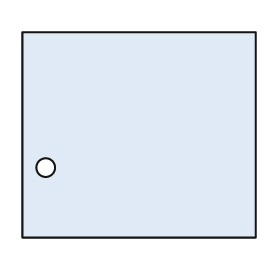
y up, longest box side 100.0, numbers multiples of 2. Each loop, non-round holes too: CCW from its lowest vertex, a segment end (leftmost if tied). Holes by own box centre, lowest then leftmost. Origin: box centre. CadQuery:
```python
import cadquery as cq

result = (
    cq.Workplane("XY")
    .moveTo(-50.0, -44.0)
    .lineTo(50.0, -44.0)
    .lineTo(50.0, 44.0)
    .lineTo(-50.0, 44.0)
    .close()
    .moveTo(-40.0, -14.0)
    .circle(4.0)
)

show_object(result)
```